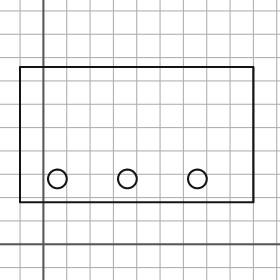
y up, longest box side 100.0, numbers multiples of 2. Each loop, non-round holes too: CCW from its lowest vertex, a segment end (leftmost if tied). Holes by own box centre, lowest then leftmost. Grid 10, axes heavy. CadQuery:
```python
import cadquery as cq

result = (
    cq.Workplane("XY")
    .moveTo(-10.0, 18.0)
    .lineTo(90.0, 18.0)
    .lineTo(90.0, 76.0)
    .lineTo(-10.0, 76.0)
    .close()
    .moveTo(6.0, 28.0)
    .circle(4.0)
    .moveTo(36.0, 28.0)
    .circle(4.0)
    .moveTo(66.0, 28.0)
    .circle(4.0)
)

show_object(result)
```